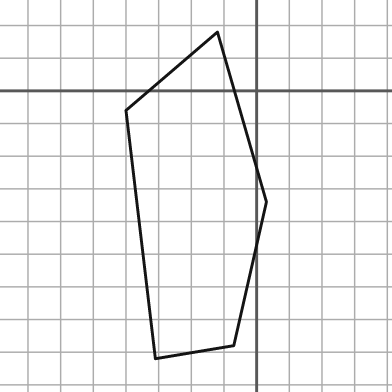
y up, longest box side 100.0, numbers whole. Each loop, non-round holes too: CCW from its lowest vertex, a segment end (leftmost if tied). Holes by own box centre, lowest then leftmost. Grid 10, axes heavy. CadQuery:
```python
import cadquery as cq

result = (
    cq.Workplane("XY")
    .moveTo(-31.0, -82.0)
    .lineTo(-7.0, -78.0)
    .lineTo(3.0, -34.0)
    .lineTo(-12.0, 18.0)
    .lineTo(-40.0, -6.0)
    .close()
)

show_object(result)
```